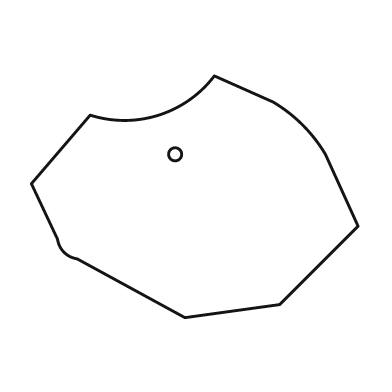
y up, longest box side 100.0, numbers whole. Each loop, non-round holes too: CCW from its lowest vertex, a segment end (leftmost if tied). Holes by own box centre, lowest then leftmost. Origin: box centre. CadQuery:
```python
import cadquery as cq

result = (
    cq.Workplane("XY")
    .moveTo(-3.0, -37.0)
    .lineTo(26.0, -33.0)
    .lineTo(50.0, -9.0)
    .lineTo(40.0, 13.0)
    .threePointArc((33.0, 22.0), (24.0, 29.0))
    .lineTo(6.0, 37.0)
    .threePointArc((-11.0, 25.0), (-32.0, 25.0))
    .lineTo(-50.0, 4.0)
    .lineTo(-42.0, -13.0)
    .threePointArc((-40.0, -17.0), (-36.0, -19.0))
    .close()
    .moveTo(-6.0, 13.0)
    .circle(2.0)
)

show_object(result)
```